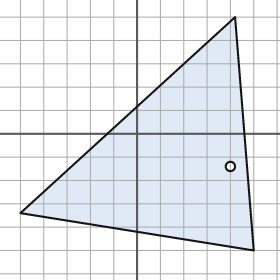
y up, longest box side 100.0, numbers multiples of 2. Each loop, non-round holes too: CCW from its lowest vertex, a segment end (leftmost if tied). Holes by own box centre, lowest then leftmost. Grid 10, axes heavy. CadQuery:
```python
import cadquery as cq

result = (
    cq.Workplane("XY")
    .moveTo(50.0, -50.0)
    .lineTo(42.0, 50.0)
    .lineTo(-50.0, -34.0)
    .close()
    .moveTo(40.0, -14.0)
    .circle(2.0)
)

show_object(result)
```